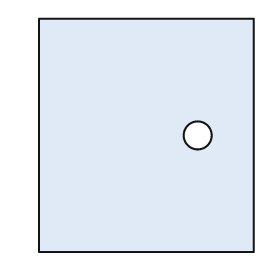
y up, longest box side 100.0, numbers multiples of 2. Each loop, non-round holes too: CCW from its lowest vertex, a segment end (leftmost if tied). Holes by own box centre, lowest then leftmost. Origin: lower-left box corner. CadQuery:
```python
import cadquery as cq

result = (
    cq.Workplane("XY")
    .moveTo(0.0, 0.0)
    .lineTo(92.0, 0.0)
    .lineTo(92.0, 100.0)
    .lineTo(0.0, 100.0)
    .close()
    .moveTo(68.0, 50.0)
    .circle(6.0)
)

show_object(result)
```